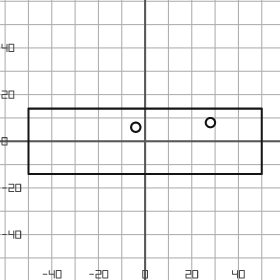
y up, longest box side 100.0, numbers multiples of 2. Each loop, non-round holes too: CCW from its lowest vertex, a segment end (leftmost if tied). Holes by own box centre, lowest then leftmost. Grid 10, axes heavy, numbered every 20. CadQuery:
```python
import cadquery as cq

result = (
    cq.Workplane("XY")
    .moveTo(-50.0, -14.0)
    .lineTo(50.0, -14.0)
    .lineTo(50.0, 14.0)
    .lineTo(-50.0, 14.0)
    .close()
    .moveTo(-4.0, 6.0)
    .circle(2.0)
    .moveTo(28.0, 8.0)
    .circle(2.0)
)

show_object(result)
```